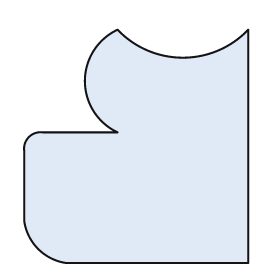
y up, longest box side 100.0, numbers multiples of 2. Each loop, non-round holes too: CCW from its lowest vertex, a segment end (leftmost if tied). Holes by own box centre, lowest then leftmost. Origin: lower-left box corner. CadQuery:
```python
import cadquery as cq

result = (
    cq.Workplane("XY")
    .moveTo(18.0, 0.0)
    .lineTo(96.0, 0.0)
    .lineTo(96.0, 100.0)
    .threePointArc((68.0, 88.0), (40.0, 100.0))
    .threePointArc((26.0, 78.0), (40.0, 56.0))
    .lineTo(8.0, 56.0)
    .threePointArc((2.0, 54.0), (0.0, 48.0))
    .lineTo(0.0, 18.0)
    .threePointArc((6.0, 6.0), (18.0, 0.0))
    .close()
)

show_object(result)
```